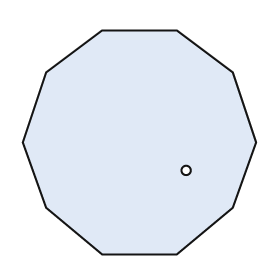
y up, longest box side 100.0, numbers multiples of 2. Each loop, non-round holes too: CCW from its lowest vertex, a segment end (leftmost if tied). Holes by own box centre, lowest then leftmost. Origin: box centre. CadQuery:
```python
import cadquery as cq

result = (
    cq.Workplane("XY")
    .moveTo(-16.0, -48.0)
    .lineTo(16.0, -48.0)
    .lineTo(40.0, -28.0)
    .lineTo(50.0, 0.0)
    .lineTo(40.0, 30.0)
    .lineTo(16.0, 48.0)
    .lineTo(-16.0, 48.0)
    .lineTo(-40.0, 30.0)
    .lineTo(-50.0, 0.0)
    .lineTo(-40.0, -28.0)
    .close()
    .moveTo(20.0, -12.0)
    .circle(2.0)
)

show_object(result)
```